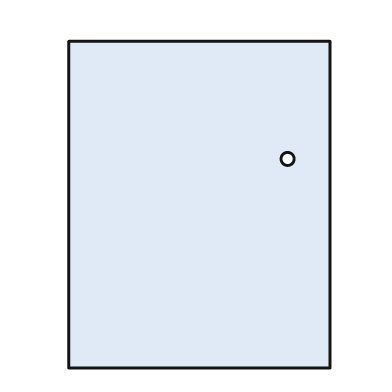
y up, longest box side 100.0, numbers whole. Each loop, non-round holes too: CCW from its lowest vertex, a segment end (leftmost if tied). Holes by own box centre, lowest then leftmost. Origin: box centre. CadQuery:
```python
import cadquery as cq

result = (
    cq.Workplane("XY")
    .moveTo(-40.0, -50.0)
    .lineTo(40.0, -50.0)
    .lineTo(40.0, 50.0)
    .lineTo(-40.0, 50.0)
    .close()
    .moveTo(27.0, 14.0)
    .circle(2.0)
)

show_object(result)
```